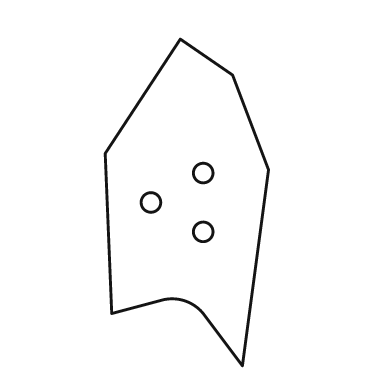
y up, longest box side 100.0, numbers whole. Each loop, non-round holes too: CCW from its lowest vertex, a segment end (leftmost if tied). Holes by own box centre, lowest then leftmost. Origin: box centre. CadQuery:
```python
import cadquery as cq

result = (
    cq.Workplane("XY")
    .moveTo(17.0, -50.0)
    .lineTo(25.0, 10.0)
    .lineTo(14.0, 39.0)
    .lineTo(-2.0, 50.0)
    .lineTo(-25.0, 15.0)
    .lineTo(-23.0, -34.0)
    .lineTo(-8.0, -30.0)
    .threePointArc((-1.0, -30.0), (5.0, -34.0))
    .close()
    .moveTo(5.0, -9.0)
    .circle(3.0)
    .moveTo(-11.0, 0.0)
    .circle(3.0)
    .moveTo(5.0, 9.0)
    .circle(3.0)
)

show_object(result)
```